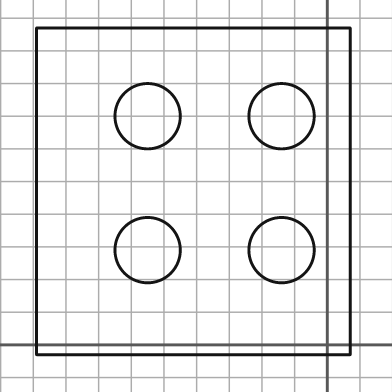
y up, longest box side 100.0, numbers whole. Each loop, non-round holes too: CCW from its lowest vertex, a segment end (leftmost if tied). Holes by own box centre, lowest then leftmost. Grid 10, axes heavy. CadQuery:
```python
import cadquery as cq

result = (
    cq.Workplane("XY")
    .moveTo(-89.0, -3.0)
    .lineTo(7.0, -3.0)
    .lineTo(7.0, 97.0)
    .lineTo(-89.0, 97.0)
    .close()
    .moveTo(-55.0, 29.0)
    .circle(10.0)
    .moveTo(-14.0, 29.0)
    .circle(10.0)
    .moveTo(-55.0, 70.0)
    .circle(10.0)
    .moveTo(-14.0, 70.0)
    .circle(10.0)
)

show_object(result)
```